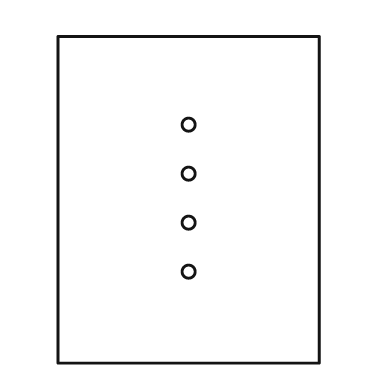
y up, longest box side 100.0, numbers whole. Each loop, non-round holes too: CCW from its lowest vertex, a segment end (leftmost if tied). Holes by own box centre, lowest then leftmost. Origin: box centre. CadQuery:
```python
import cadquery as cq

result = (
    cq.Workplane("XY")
    .moveTo(-40.0, -50.0)
    .lineTo(40.0, -50.0)
    .lineTo(40.0, 50.0)
    .lineTo(-40.0, 50.0)
    .close()
    .moveTo(0.0, -22.0)
    .circle(2.0)
    .moveTo(0.0, -7.0)
    .circle(2.0)
    .moveTo(0.0, 8.0)
    .circle(2.0)
    .moveTo(0.0, 23.0)
    .circle(2.0)
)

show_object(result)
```